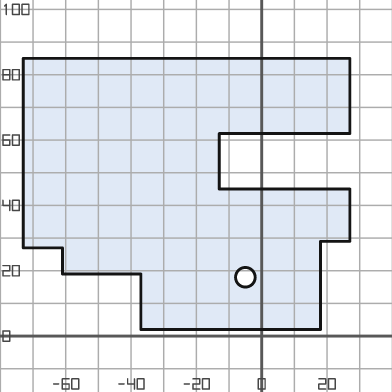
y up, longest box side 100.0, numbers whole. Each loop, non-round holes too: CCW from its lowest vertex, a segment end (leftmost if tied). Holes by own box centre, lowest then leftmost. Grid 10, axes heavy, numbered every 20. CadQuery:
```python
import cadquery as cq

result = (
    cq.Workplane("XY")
    .moveTo(-37.0, 2.0)
    .lineTo(18.0, 2.0)
    .lineTo(18.0, 29.0)
    .lineTo(27.0, 29.0)
    .lineTo(27.0, 45.0)
    .lineTo(-13.0, 45.0)
    .lineTo(-13.0, 62.0)
    .lineTo(27.0, 62.0)
    .lineTo(27.0, 85.0)
    .lineTo(-73.0, 85.0)
    .lineTo(-73.0, 27.0)
    .lineTo(-61.0, 27.0)
    .lineTo(-61.0, 19.0)
    .lineTo(-37.0, 19.0)
    .close()
    .moveTo(-5.0, 18.0)
    .circle(3.0)
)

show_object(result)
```